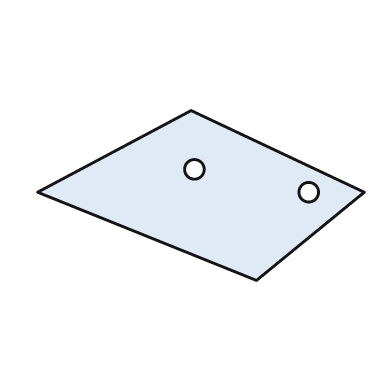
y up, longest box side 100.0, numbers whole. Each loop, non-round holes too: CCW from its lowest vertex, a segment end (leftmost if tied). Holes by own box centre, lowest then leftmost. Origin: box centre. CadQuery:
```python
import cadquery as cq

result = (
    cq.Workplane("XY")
    .moveTo(17.0, -26.0)
    .lineTo(50.0, 1.0)
    .lineTo(-3.0, 26.0)
    .lineTo(-50.0, 1.0)
    .close()
    .moveTo(33.0, 1.0)
    .circle(3.0)
    .moveTo(-2.0, 8.0)
    .circle(3.0)
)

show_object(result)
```